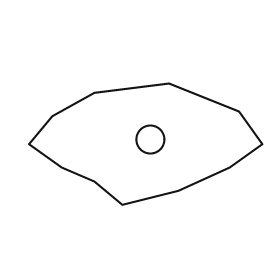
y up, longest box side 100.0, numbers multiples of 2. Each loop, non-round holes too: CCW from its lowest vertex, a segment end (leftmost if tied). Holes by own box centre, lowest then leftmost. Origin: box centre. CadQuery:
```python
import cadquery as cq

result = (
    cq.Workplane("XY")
    .moveTo(-10.0, -26.0)
    .lineTo(14.0, -20.0)
    .lineTo(36.0, -10.0)
    .lineTo(50.0, 0.0)
    .lineTo(40.0, 14.0)
    .lineTo(10.0, 26.0)
    .lineTo(-22.0, 22.0)
    .lineTo(-40.0, 12.0)
    .lineTo(-50.0, 0.0)
    .lineTo(-36.0, -10.0)
    .lineTo(-22.0, -16.0)
    .close()
    .moveTo(2.0, 2.0)
    .circle(6.0)
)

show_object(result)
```